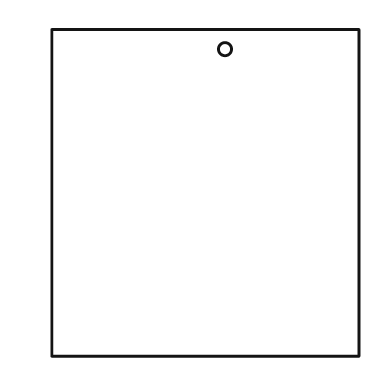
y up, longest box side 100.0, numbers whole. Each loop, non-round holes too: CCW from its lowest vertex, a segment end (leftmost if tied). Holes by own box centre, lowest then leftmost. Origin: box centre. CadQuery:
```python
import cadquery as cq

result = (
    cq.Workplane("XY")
    .moveTo(-47.0, -50.0)
    .lineTo(47.0, -50.0)
    .lineTo(47.0, 50.0)
    .lineTo(-47.0, 50.0)
    .close()
    .moveTo(6.0, 44.0)
    .circle(2.0)
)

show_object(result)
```